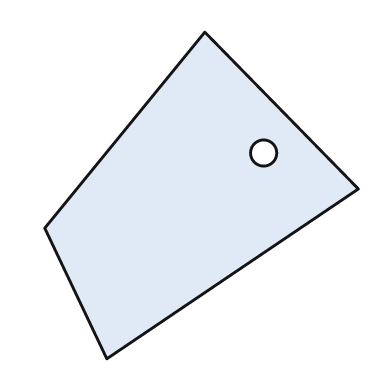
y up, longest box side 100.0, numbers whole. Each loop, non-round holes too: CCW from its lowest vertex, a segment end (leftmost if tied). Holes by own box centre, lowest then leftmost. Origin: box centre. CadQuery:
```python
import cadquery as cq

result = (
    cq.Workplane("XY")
    .moveTo(-29.0, -50.0)
    .lineTo(48.0, 2.0)
    .lineTo(1.0, 50.0)
    .lineTo(-48.0, -10.0)
    .close()
    .moveTo(19.0, 13.0)
    .circle(4.0)
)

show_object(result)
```